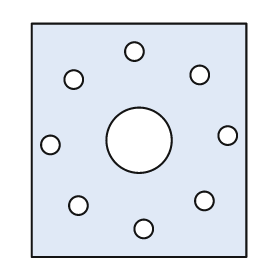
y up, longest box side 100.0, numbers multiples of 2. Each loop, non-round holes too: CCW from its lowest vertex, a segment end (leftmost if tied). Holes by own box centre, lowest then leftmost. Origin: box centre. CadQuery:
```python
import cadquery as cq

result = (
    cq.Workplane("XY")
    .moveTo(-46.0, -50.0)
    .lineTo(46.0, -50.0)
    .lineTo(46.0, 50.0)
    .lineTo(-46.0, 50.0)
    .close()
    .moveTo(2.0, -38.0)
    .circle(4.0)
    .moveTo(-26.0, -28.0)
    .circle(4.0)
    .moveTo(28.0, -26.0)
    .circle(4.0)
    .moveTo(-38.0, -2.0)
    .circle(4.0)
    .moveTo(0.0, 0.0)
    .circle(14.0)
    .moveTo(38.0, 2.0)
    .circle(4.0)
    .moveTo(-28.0, 26.0)
    .circle(4.0)
    .moveTo(26.0, 28.0)
    .circle(4.0)
    .moveTo(-2.0, 38.0)
    .circle(4.0)
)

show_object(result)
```